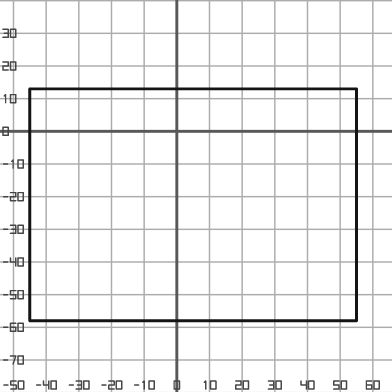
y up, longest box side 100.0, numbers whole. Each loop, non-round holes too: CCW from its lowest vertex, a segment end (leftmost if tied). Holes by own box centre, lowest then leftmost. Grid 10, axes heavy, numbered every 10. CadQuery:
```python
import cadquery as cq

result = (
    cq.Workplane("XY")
    .moveTo(-45.0, -58.0)
    .lineTo(55.0, -58.0)
    .lineTo(55.0, 13.0)
    .lineTo(-45.0, 13.0)
    .close()
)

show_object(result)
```